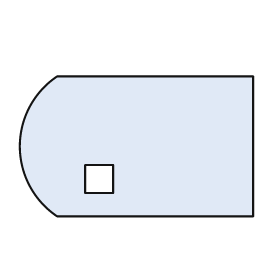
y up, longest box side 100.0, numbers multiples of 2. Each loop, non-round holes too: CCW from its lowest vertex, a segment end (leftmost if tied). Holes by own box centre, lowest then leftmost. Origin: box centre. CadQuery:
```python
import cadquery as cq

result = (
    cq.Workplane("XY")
    .moveTo(-34.0, -30.0)
    .lineTo(50.0, -30.0)
    .lineTo(50.0, 30.0)
    .lineTo(-34.0, 30.0)
    .threePointArc((-50.0, 0.0), (-34.0, -30.0))
    .close()
    .moveTo(-22.0, -20.0)
    .lineTo(-10.0, -20.0)
    .lineTo(-10.0, -8.0)
    .lineTo(-22.0, -8.0)
    .close()
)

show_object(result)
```